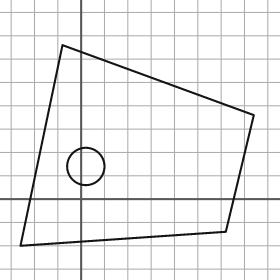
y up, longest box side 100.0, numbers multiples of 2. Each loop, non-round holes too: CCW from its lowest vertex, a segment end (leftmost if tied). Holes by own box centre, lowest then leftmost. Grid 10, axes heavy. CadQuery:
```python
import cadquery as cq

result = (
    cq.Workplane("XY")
    .moveTo(-26.0, -20.0)
    .lineTo(62.0, -14.0)
    .lineTo(74.0, 36.0)
    .lineTo(-8.0, 66.0)
    .close()
    .moveTo(2.0, 14.0)
    .circle(8.0)
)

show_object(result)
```